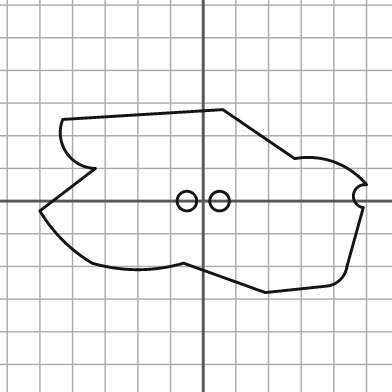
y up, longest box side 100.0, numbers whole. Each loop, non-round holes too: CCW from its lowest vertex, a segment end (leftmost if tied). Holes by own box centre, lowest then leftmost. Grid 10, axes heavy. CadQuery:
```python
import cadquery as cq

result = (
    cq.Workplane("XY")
    .moveTo(19.0, -28.0)
    .lineTo(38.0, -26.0)
    .threePointArc((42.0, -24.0), (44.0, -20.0))
    .lineTo(49.0, -2.0)
    .threePointArc((46.0, 2.0), (50.0, 5.0))
    .threePointArc((40.0, 12.0), (28.0, 13.0))
    .lineTo(6.0, 28.0)
    .lineTo(-43.0, 25.0)
    .threePointArc((-42.0, 15.0), (-33.0, 10.0))
    .lineTo(-50.0, -3.0)
    .threePointArc((-43.0, -12.0), (-34.0, -19.0))
    .threePointArc((-20.0, -21.0), (-6.0, -19.0))
    .close()
    .moveTo(-5.0, 0.0)
    .circle(3.0)
    .moveTo(5.0, 0.0)
    .circle(3.0)
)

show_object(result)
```